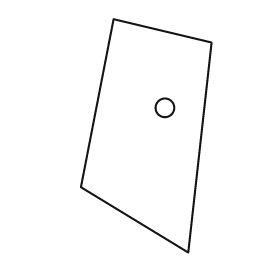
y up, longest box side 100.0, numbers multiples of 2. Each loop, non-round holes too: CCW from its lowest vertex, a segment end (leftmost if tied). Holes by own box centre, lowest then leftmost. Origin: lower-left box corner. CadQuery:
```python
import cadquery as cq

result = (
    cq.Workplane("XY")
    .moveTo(46.0, 0.0)
    .lineTo(56.0, 90.0)
    .lineTo(14.0, 100.0)
    .lineTo(0.0, 28.0)
    .close()
    .moveTo(36.0, 62.0)
    .circle(4.0)
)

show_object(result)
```